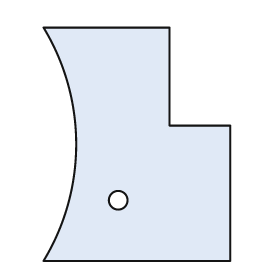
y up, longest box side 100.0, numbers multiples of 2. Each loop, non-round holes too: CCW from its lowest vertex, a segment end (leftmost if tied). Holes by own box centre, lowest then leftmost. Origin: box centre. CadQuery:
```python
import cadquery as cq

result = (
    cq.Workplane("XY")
    .moveTo(-40.0, -50.0)
    .lineTo(40.0, -50.0)
    .lineTo(40.0, 8.0)
    .lineTo(14.0, 8.0)
    .lineTo(14.0, 50.0)
    .lineTo(-40.0, 50.0)
    .threePointArc((-26.0, 0.0), (-40.0, -50.0))
    .close()
    .moveTo(-8.0, -24.0)
    .circle(4.0)
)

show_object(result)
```